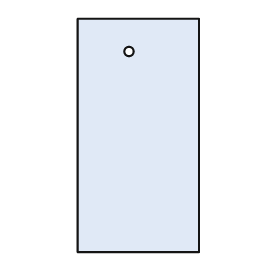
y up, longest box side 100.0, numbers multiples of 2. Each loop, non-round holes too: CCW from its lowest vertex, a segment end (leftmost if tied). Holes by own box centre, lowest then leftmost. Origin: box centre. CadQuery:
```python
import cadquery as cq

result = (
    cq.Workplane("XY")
    .moveTo(-26.0, -50.0)
    .lineTo(26.0, -50.0)
    .lineTo(26.0, 50.0)
    .lineTo(-26.0, 50.0)
    .close()
    .moveTo(-4.0, 36.0)
    .circle(2.0)
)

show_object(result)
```